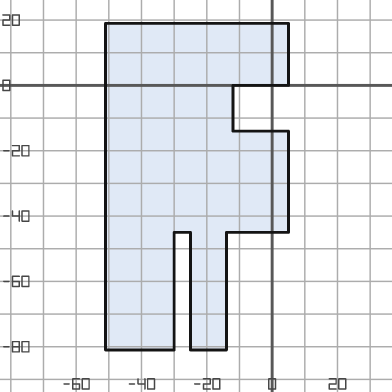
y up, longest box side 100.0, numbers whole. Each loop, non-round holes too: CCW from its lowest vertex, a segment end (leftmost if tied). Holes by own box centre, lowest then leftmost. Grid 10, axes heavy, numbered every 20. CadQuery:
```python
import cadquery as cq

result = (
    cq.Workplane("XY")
    .moveTo(-51.0, -81.0)
    .lineTo(-30.0, -81.0)
    .lineTo(-30.0, -45.0)
    .lineTo(-25.0, -45.0)
    .lineTo(-25.0, -81.0)
    .lineTo(-14.0, -81.0)
    .lineTo(-14.0, -45.0)
    .lineTo(5.0, -45.0)
    .lineTo(5.0, -14.0)
    .lineTo(-12.0, -14.0)
    .lineTo(-12.0, 0.0)
    .lineTo(5.0, 0.0)
    .lineTo(5.0, 19.0)
    .lineTo(-51.0, 19.0)
    .close()
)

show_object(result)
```